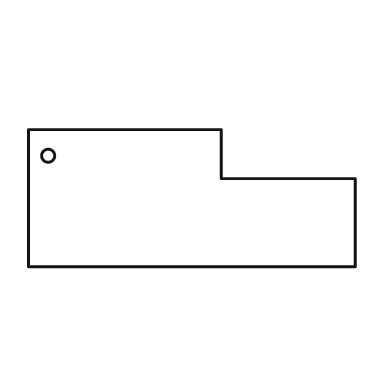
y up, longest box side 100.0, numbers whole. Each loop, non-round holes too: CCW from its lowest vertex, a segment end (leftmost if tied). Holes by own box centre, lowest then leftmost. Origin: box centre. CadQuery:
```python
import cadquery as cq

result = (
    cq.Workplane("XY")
    .moveTo(-50.0, -21.0)
    .lineTo(50.0, -21.0)
    .lineTo(50.0, 6.0)
    .lineTo(9.0, 6.0)
    .lineTo(9.0, 21.0)
    .lineTo(-50.0, 21.0)
    .close()
    .moveTo(-44.0, 13.0)
    .circle(2.0)
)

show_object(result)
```